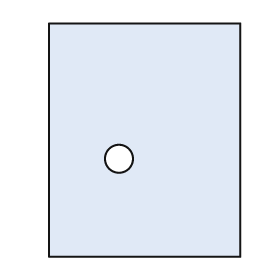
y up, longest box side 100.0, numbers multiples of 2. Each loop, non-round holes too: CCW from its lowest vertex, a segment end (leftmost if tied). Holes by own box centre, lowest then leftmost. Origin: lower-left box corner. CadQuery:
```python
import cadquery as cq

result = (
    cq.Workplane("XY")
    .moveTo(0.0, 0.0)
    .lineTo(82.0, 0.0)
    .lineTo(82.0, 100.0)
    .lineTo(0.0, 100.0)
    .close()
    .moveTo(30.0, 42.0)
    .circle(6.0)
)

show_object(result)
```